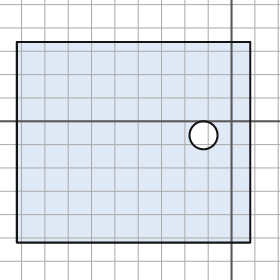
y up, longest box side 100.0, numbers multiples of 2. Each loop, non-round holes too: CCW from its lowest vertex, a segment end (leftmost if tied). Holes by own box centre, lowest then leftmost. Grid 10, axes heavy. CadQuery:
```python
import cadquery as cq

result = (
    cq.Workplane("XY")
    .moveTo(-92.0, -52.0)
    .lineTo(8.0, -52.0)
    .lineTo(8.0, 34.0)
    .lineTo(-92.0, 34.0)
    .close()
    .moveTo(-12.0, -6.0)
    .circle(6.0)
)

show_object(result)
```